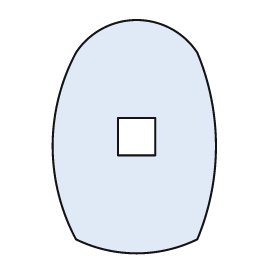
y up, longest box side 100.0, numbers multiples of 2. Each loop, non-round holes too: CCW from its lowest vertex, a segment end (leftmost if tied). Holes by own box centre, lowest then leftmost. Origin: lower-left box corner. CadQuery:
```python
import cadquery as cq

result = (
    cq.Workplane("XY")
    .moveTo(10.0, 6.0)
    .threePointArc((36.0, 0.0), (62.0, 6.0))
    .threePointArc((70.0, 46.0), (62.0, 86.0))
    .threePointArc((36.0, 100.0), (10.0, 86.0))
    .threePointArc((0.0, 46.0), (10.0, 6.0))
    .close()
    .moveTo(28.0, 42.0)
    .lineTo(44.0, 42.0)
    .lineTo(44.0, 58.0)
    .lineTo(28.0, 58.0)
    .close()
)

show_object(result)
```